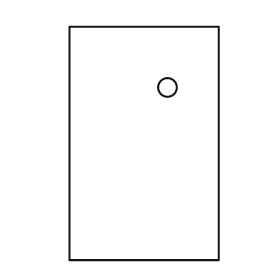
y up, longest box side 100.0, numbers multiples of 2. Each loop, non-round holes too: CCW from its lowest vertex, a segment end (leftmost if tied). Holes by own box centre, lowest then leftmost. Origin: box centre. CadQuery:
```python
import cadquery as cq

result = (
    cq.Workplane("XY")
    .moveTo(-32.0, -50.0)
    .lineTo(32.0, -50.0)
    .lineTo(32.0, 50.0)
    .lineTo(-32.0, 50.0)
    .close()
    .moveTo(10.0, 24.0)
    .circle(4.0)
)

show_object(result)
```